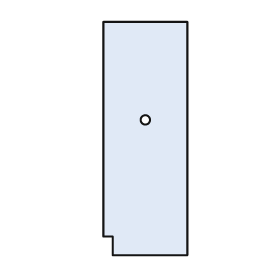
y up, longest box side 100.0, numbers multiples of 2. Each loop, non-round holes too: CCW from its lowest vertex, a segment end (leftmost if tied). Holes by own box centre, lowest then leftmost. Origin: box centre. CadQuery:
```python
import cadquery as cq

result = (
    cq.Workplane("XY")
    .moveTo(-14.0, -50.0)
    .lineTo(18.0, -50.0)
    .lineTo(18.0, 50.0)
    .lineTo(-18.0, 50.0)
    .lineTo(-18.0, -42.0)
    .lineTo(-14.0, -42.0)
    .close()
    .moveTo(0.0, 8.0)
    .circle(2.0)
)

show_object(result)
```